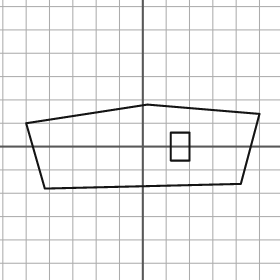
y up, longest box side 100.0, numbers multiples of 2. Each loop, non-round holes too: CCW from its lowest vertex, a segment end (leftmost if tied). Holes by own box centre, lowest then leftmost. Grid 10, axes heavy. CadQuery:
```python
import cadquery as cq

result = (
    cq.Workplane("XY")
    .moveTo(-42.0, -18.0)
    .lineTo(42.0, -16.0)
    .lineTo(50.0, 14.0)
    .lineTo(2.0, 18.0)
    .lineTo(-50.0, 10.0)
    .close()
    .moveTo(12.0, -6.0)
    .lineTo(20.0, -6.0)
    .lineTo(20.0, 6.0)
    .lineTo(12.0, 6.0)
    .close()
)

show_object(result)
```